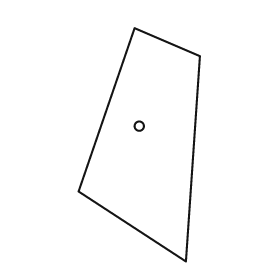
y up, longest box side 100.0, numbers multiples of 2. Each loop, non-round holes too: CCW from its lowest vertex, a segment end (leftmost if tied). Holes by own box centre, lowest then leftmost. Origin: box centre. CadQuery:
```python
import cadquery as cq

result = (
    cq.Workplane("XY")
    .moveTo(20.0, -50.0)
    .lineTo(26.0, 38.0)
    .lineTo(-2.0, 50.0)
    .lineTo(-26.0, -20.0)
    .close()
    .moveTo(0.0, 8.0)
    .circle(2.0)
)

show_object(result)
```